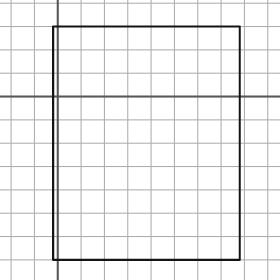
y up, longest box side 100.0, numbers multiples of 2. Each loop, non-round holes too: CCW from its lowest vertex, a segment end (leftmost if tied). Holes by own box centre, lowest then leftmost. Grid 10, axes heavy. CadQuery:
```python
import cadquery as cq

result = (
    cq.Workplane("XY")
    .moveTo(-2.0, -70.0)
    .lineTo(78.0, -70.0)
    .lineTo(78.0, 30.0)
    .lineTo(-2.0, 30.0)
    .close()
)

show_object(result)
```